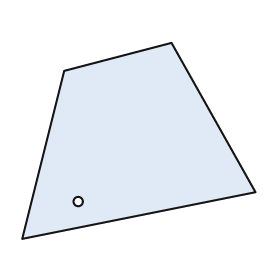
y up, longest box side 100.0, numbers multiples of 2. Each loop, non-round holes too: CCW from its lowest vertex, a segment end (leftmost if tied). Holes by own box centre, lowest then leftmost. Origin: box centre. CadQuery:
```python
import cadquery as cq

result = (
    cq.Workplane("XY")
    .moveTo(-50.0, -42.0)
    .lineTo(50.0, -22.0)
    .lineTo(14.0, 42.0)
    .lineTo(-32.0, 30.0)
    .close()
    .moveTo(-26.0, -26.0)
    .circle(2.0)
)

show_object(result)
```